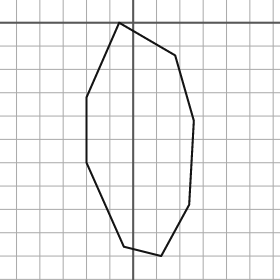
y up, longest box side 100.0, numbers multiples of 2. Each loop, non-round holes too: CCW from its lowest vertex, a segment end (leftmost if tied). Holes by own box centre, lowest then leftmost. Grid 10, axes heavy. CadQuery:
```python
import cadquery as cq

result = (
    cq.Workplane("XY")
    .moveTo(12.0, -100.0)
    .lineTo(24.0, -78.0)
    .lineTo(26.0, -42.0)
    .lineTo(18.0, -14.0)
    .lineTo(-6.0, 0.0)
    .lineTo(-20.0, -32.0)
    .lineTo(-20.0, -60.0)
    .lineTo(-4.0, -96.0)
    .close()
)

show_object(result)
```